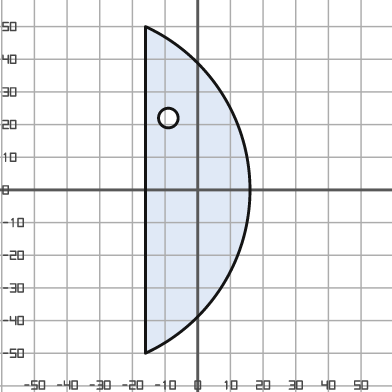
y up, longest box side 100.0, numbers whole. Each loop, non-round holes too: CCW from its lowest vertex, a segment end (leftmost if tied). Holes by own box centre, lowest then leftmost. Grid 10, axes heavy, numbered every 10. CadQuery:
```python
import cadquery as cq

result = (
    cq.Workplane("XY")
    .moveTo(-16.0, -50.0)
    .threePointArc((16.0, 0.0), (-16.0, 50.0))
    .close()
    .moveTo(-9.0, 22.0)
    .circle(3.0)
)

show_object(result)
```